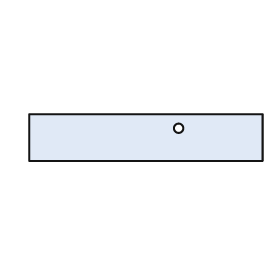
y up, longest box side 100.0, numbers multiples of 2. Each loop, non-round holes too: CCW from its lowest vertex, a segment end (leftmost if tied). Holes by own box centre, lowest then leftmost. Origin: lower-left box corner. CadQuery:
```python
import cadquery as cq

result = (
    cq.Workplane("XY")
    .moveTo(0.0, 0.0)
    .lineTo(100.0, 0.0)
    .lineTo(100.0, 20.0)
    .lineTo(0.0, 20.0)
    .close()
    .moveTo(64.0, 14.0)
    .circle(2.0)
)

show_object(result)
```